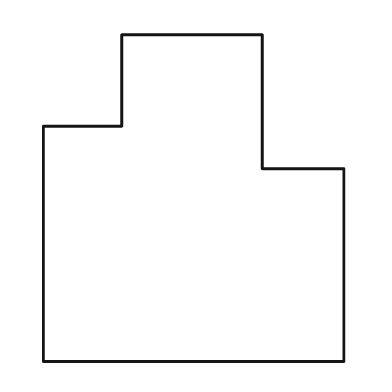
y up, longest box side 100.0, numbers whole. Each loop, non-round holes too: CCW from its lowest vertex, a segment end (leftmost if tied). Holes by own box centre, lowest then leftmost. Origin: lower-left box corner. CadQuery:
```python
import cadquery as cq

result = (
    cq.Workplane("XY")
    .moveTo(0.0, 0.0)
    .lineTo(92.0, 0.0)
    .lineTo(92.0, 59.0)
    .lineTo(67.0, 59.0)
    .lineTo(67.0, 100.0)
    .lineTo(24.0, 100.0)
    .lineTo(24.0, 72.0)
    .lineTo(0.0, 72.0)
    .close()
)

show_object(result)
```